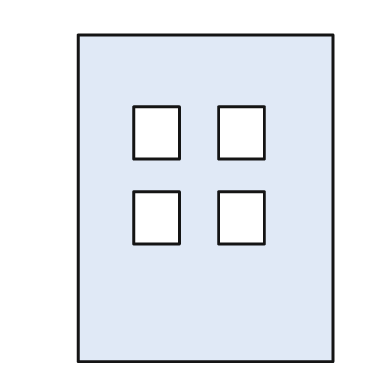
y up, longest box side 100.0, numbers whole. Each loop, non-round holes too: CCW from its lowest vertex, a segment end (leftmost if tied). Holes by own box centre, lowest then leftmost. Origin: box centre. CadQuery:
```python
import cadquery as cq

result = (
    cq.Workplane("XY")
    .moveTo(-39.0, -50.0)
    .lineTo(39.0, -50.0)
    .lineTo(39.0, 50.0)
    .lineTo(-39.0, 50.0)
    .close()
    .moveTo(-22.0, -14.0)
    .lineTo(-8.0, -14.0)
    .lineTo(-8.0, 2.0)
    .lineTo(-22.0, 2.0)
    .close()
    .moveTo(4.0, -14.0)
    .lineTo(18.0, -14.0)
    .lineTo(18.0, 2.0)
    .lineTo(4.0, 2.0)
    .close()
    .moveTo(-22.0, 12.0)
    .lineTo(-8.0, 12.0)
    .lineTo(-8.0, 28.0)
    .lineTo(-22.0, 28.0)
    .close()
    .moveTo(4.0, 12.0)
    .lineTo(18.0, 12.0)
    .lineTo(18.0, 28.0)
    .lineTo(4.0, 28.0)
    .close()
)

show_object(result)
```